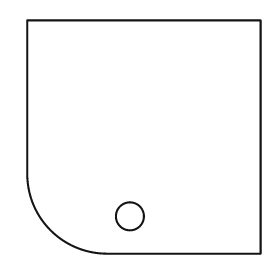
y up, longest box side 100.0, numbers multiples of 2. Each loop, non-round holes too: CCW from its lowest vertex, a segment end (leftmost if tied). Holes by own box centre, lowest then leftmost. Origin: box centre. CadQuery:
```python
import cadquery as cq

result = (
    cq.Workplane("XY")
    .moveTo(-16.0, -50.0)
    .lineTo(50.0, -50.0)
    .lineTo(50.0, 50.0)
    .lineTo(-50.0, 50.0)
    .lineTo(-50.0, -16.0)
    .threePointArc((-40.0, -40.0), (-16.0, -50.0))
    .close()
    .moveTo(-6.0, -34.0)
    .circle(6.0)
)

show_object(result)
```